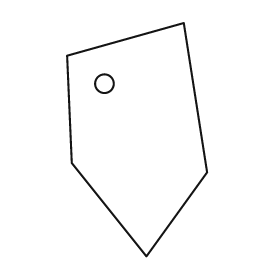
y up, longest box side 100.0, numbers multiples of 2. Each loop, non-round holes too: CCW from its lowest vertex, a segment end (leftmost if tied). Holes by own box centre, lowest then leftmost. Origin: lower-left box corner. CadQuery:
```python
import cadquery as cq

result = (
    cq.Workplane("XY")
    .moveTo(34.0, 0.0)
    .lineTo(60.0, 36.0)
    .lineTo(50.0, 100.0)
    .lineTo(0.0, 86.0)
    .lineTo(2.0, 40.0)
    .close()
    .moveTo(16.0, 74.0)
    .circle(4.0)
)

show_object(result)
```